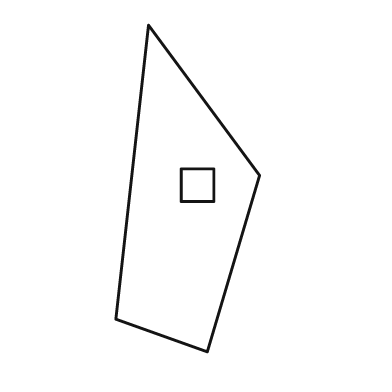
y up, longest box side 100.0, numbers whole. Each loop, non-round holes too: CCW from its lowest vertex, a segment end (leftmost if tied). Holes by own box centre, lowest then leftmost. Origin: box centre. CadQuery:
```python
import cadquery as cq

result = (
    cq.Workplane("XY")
    .moveTo(6.0, -50.0)
    .lineTo(22.0, 4.0)
    .lineTo(-12.0, 50.0)
    .lineTo(-22.0, -40.0)
    .close()
    .moveTo(-2.0, -4.0)
    .lineTo(8.0, -4.0)
    .lineTo(8.0, 6.0)
    .lineTo(-2.0, 6.0)
    .close()
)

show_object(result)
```